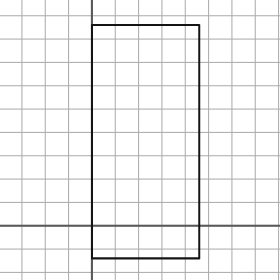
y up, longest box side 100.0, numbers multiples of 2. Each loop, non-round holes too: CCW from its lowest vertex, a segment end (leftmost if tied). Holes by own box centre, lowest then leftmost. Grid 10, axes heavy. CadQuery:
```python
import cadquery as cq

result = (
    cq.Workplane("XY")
    .moveTo(0.0, -14.0)
    .lineTo(46.0, -14.0)
    .lineTo(46.0, 86.0)
    .lineTo(0.0, 86.0)
    .close()
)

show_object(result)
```